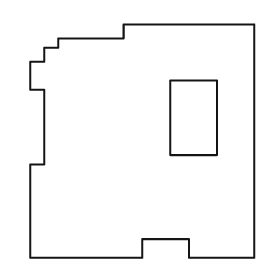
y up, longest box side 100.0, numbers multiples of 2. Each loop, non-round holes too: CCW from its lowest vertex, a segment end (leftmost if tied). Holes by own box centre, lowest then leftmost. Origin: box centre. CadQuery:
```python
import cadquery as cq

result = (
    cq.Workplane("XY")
    .moveTo(-48.0, -50.0)
    .lineTo(0.0, -50.0)
    .lineTo(0.0, -42.0)
    .lineTo(20.0, -42.0)
    .lineTo(20.0, -50.0)
    .lineTo(48.0, -50.0)
    .lineTo(48.0, 50.0)
    .lineTo(-8.0, 50.0)
    .lineTo(-8.0, 44.0)
    .lineTo(-36.0, 44.0)
    .lineTo(-36.0, 40.0)
    .lineTo(-42.0, 40.0)
    .lineTo(-42.0, 34.0)
    .lineTo(-48.0, 34.0)
    .lineTo(-48.0, 22.0)
    .lineTo(-42.0, 22.0)
    .lineTo(-42.0, -10.0)
    .lineTo(-48.0, -10.0)
    .close()
    .moveTo(12.0, -6.0)
    .lineTo(32.0, -6.0)
    .lineTo(32.0, 26.0)
    .lineTo(12.0, 26.0)
    .close()
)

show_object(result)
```